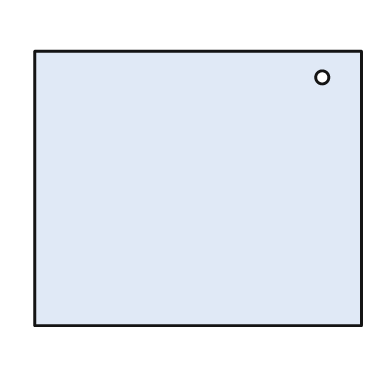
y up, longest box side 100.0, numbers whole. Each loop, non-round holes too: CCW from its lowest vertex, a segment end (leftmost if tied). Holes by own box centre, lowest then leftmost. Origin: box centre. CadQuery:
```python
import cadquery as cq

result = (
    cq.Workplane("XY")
    .moveTo(-50.0, -42.0)
    .lineTo(50.0, -42.0)
    .lineTo(50.0, 42.0)
    .lineTo(-50.0, 42.0)
    .close()
    .moveTo(38.0, 34.0)
    .circle(2.0)
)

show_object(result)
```